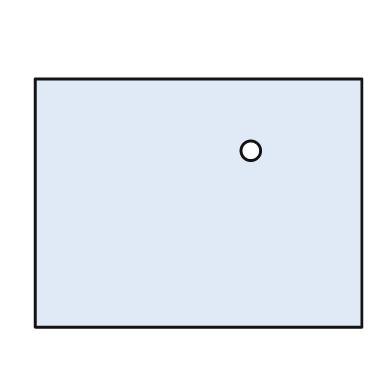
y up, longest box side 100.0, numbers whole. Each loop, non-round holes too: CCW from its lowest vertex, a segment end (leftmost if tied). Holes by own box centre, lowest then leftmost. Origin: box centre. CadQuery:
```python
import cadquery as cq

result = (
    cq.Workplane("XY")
    .moveTo(-50.0, -38.0)
    .lineTo(50.0, -38.0)
    .lineTo(50.0, 38.0)
    .lineTo(-50.0, 38.0)
    .close()
    .moveTo(16.0, 16.0)
    .circle(3.0)
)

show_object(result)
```